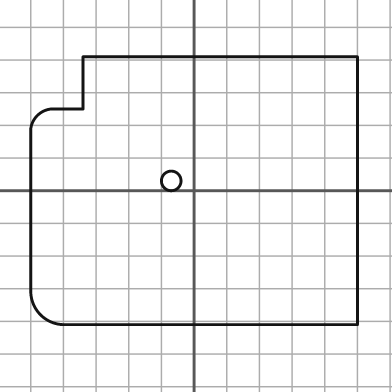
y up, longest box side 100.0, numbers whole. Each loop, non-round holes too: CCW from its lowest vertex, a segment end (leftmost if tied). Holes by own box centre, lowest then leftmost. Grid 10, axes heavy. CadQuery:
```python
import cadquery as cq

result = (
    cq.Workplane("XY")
    .moveTo(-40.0, -41.0)
    .lineTo(50.0, -41.0)
    .lineTo(50.0, 41.0)
    .lineTo(-34.0, 41.0)
    .lineTo(-34.0, 25.0)
    .lineTo(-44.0, 25.0)
    .threePointArc((-48.0, 23.0), (-50.0, 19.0))
    .lineTo(-50.0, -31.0)
    .threePointArc((-47.0, -38.0), (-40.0, -41.0))
    .close()
    .moveTo(-7.0, 3.0)
    .circle(3.0)
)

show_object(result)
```